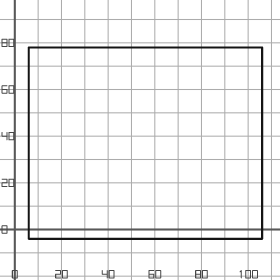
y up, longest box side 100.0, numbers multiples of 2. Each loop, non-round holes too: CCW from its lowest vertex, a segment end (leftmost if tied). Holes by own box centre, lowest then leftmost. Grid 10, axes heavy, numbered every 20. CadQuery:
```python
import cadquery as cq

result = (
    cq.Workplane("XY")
    .moveTo(6.0, -4.0)
    .lineTo(106.0, -4.0)
    .lineTo(106.0, 78.0)
    .lineTo(6.0, 78.0)
    .close()
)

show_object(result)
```